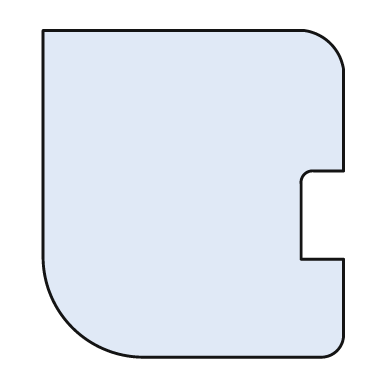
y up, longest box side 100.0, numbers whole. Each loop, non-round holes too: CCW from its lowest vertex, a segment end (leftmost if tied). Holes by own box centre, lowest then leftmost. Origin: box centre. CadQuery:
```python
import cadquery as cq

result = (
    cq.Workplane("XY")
    .moveTo(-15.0, -50.0)
    .lineTo(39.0, -50.0)
    .threePointArc((44.0, -48.0), (46.0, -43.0))
    .lineTo(46.0, -20.0)
    .lineTo(33.0, -20.0)
    .lineTo(33.0, 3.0)
    .threePointArc((34.0, 6.0), (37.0, 7.0))
    .lineTo(46.0, 7.0)
    .lineTo(46.0, 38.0)
    .threePointArc((42.0, 46.0), (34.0, 50.0))
    .lineTo(-46.0, 50.0)
    .lineTo(-46.0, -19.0)
    .threePointArc((-37.0, -41.0), (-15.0, -50.0))
    .close()
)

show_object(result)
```